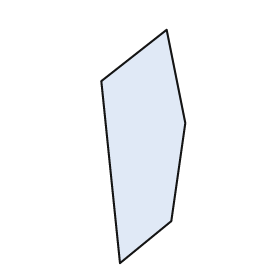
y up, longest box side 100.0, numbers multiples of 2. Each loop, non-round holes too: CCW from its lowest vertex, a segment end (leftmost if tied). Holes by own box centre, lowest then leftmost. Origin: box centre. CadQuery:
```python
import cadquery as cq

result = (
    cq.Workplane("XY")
    .moveTo(-10.0, -50.0)
    .lineTo(12.0, -32.0)
    .lineTo(18.0, 10.0)
    .lineTo(10.0, 50.0)
    .lineTo(-18.0, 28.0)
    .close()
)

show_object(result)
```